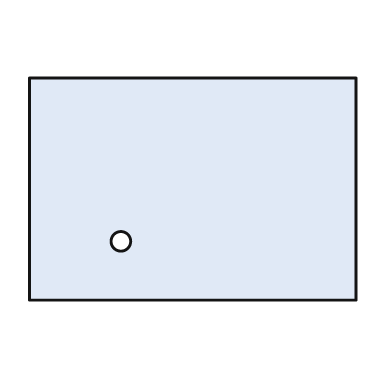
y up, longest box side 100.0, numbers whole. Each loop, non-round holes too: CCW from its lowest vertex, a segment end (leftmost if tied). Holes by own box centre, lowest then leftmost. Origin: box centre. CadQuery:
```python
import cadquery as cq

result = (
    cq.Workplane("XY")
    .moveTo(-50.0, -34.0)
    .lineTo(50.0, -34.0)
    .lineTo(50.0, 34.0)
    .lineTo(-50.0, 34.0)
    .close()
    .moveTo(-22.0, -16.0)
    .circle(3.0)
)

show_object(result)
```